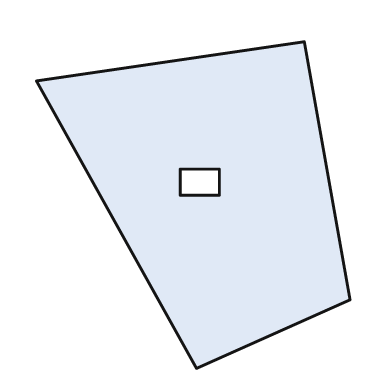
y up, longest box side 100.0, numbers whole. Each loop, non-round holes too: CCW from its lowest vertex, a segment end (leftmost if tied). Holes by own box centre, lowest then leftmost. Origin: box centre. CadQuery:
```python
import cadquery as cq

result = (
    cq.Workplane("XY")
    .moveTo(1.0, -50.0)
    .lineTo(48.0, -29.0)
    .lineTo(34.0, 50.0)
    .lineTo(-48.0, 38.0)
    .close()
    .moveTo(-4.0, 3.0)
    .lineTo(8.0, 3.0)
    .lineTo(8.0, 11.0)
    .lineTo(-4.0, 11.0)
    .close()
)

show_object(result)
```